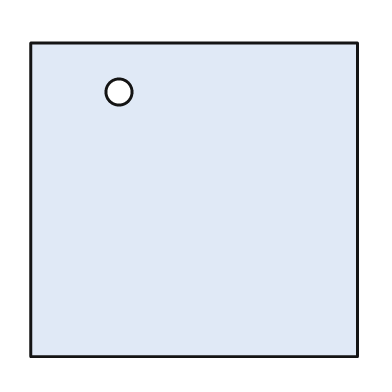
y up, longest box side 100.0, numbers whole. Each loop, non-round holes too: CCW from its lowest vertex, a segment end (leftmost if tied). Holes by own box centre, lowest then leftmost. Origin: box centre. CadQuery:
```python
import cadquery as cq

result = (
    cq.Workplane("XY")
    .moveTo(-50.0, -48.0)
    .lineTo(50.0, -48.0)
    .lineTo(50.0, 48.0)
    .lineTo(-50.0, 48.0)
    .close()
    .moveTo(-23.0, 33.0)
    .circle(4.0)
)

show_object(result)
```